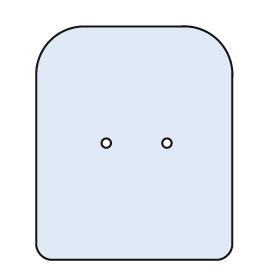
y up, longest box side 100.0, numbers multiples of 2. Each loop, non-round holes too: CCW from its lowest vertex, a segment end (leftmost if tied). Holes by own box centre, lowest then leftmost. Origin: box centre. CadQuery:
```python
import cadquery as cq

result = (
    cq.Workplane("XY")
    .moveTo(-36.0, -50.0)
    .lineTo(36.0, -50.0)
    .threePointArc((40.0, -48.0), (42.0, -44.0))
    .lineTo(42.0, 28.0)
    .threePointArc((36.0, 44.0), (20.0, 50.0))
    .lineTo(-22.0, 50.0)
    .threePointArc((-36.0, 44.0), (-42.0, 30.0))
    .lineTo(-42.0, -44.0)
    .threePointArc((-40.0, -48.0), (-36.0, -50.0))
    .close()
    .moveTo(-12.0, 0.0)
    .circle(2.0)
    .moveTo(14.0, 0.0)
    .circle(2.0)
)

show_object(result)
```